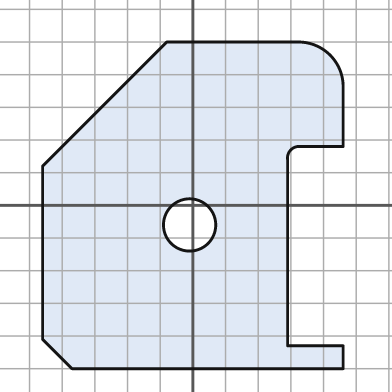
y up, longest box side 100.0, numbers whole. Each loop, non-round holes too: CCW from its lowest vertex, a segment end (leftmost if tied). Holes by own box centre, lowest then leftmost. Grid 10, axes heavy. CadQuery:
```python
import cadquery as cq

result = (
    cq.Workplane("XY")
    .moveTo(-37.0, -50.0)
    .lineTo(46.0, -50.0)
    .lineTo(46.0, -43.0)
    .lineTo(29.0, -43.0)
    .lineTo(29.0, 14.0)
    .threePointArc((30.0, 17.0), (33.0, 18.0))
    .lineTo(46.0, 18.0)
    .lineTo(46.0, 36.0)
    .threePointArc((42.0, 46.0), (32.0, 50.0))
    .lineTo(-8.0, 50.0)
    .lineTo(-46.0, 12.0)
    .lineTo(-46.0, -41.0)
    .close()
    .moveTo(-1.0, -6.0)
    .circle(8.0)
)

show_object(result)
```